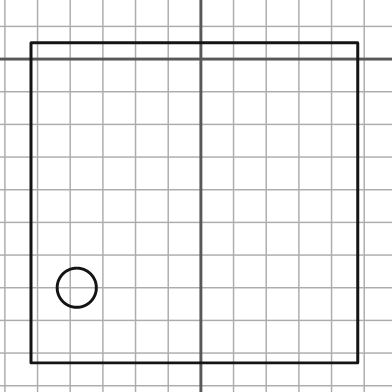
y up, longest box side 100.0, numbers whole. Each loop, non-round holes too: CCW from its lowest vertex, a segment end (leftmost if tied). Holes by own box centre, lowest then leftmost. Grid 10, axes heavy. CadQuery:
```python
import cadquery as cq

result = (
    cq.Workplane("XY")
    .moveTo(-52.0, -93.0)
    .lineTo(48.0, -93.0)
    .lineTo(48.0, 5.0)
    .lineTo(-52.0, 5.0)
    .close()
    .moveTo(-38.0, -70.0)
    .circle(6.0)
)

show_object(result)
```